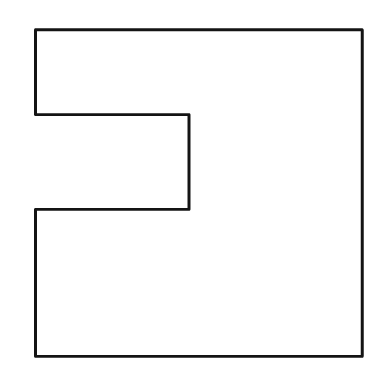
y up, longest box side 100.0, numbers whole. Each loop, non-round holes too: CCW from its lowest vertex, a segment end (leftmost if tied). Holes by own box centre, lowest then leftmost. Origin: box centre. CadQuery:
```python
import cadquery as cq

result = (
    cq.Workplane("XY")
    .moveTo(-50.0, -50.0)
    .lineTo(50.0, -50.0)
    .lineTo(50.0, 50.0)
    .lineTo(-50.0, 50.0)
    .lineTo(-50.0, 24.0)
    .lineTo(-3.0, 24.0)
    .lineTo(-3.0, -5.0)
    .lineTo(-50.0, -5.0)
    .close()
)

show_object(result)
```